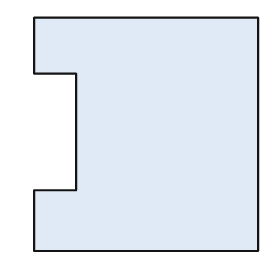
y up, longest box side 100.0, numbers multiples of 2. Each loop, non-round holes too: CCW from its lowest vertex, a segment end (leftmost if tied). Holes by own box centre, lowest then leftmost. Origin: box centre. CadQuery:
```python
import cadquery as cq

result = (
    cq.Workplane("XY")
    .moveTo(-48.0, -50.0)
    .lineTo(48.0, -50.0)
    .lineTo(48.0, 50.0)
    .lineTo(-48.0, 50.0)
    .lineTo(-48.0, 26.0)
    .lineTo(-30.0, 26.0)
    .lineTo(-30.0, -24.0)
    .lineTo(-48.0, -24.0)
    .close()
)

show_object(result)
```